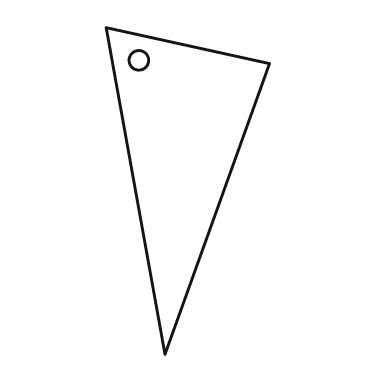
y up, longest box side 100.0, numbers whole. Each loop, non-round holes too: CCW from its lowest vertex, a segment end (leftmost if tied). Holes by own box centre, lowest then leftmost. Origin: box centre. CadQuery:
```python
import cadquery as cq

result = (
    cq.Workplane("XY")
    .moveTo(-7.0, -50.0)
    .lineTo(25.0, 39.0)
    .lineTo(-25.0, 50.0)
    .close()
    .moveTo(-15.0, 40.0)
    .circle(3.0)
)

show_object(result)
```